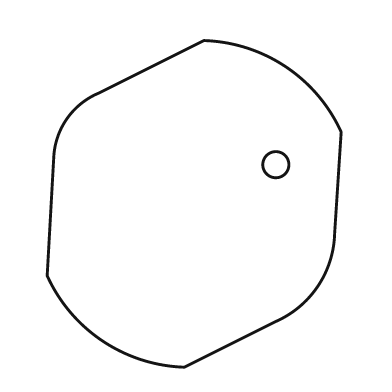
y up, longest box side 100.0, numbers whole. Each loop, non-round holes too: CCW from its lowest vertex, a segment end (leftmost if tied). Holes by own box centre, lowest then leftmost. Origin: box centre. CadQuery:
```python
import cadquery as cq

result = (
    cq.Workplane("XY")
    .moveTo(-3.0, -50.0)
    .lineTo(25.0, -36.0)
    .threePointArc((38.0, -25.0), (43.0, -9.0))
    .lineTo(45.0, 22.0)
    .threePointArc((28.0, 42.0), (3.0, 50.0))
    .lineTo(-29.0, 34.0)
    .threePointArc((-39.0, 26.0), (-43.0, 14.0))
    .lineTo(-45.0, -22.0)
    .threePointArc((-28.0, -42.0), (-3.0, -50.0))
    .close()
    .moveTo(25.0, 12.0)
    .circle(4.0)
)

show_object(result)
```